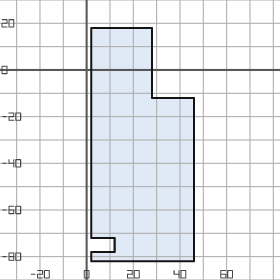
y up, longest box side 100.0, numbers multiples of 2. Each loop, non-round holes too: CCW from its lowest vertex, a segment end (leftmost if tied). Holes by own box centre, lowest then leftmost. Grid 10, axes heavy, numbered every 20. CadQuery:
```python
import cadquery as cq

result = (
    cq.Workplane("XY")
    .moveTo(2.0, -82.0)
    .lineTo(46.0, -82.0)
    .lineTo(46.0, -12.0)
    .lineTo(28.0, -12.0)
    .lineTo(28.0, 18.0)
    .lineTo(2.0, 18.0)
    .lineTo(2.0, -72.0)
    .lineTo(12.0, -72.0)
    .lineTo(12.0, -78.0)
    .lineTo(2.0, -78.0)
    .close()
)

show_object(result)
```